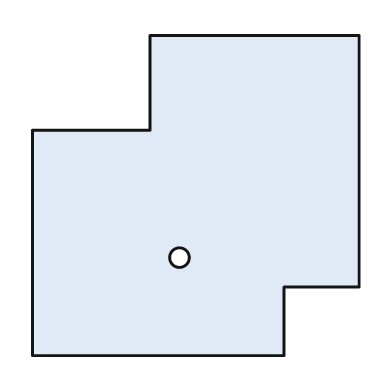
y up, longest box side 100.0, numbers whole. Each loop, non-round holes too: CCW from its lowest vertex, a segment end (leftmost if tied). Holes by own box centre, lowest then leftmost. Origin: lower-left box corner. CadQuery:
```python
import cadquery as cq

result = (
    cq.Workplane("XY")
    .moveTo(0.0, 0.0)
    .lineTo(77.0, 0.0)
    .lineTo(77.0, 21.0)
    .lineTo(100.0, 21.0)
    .lineTo(100.0, 98.0)
    .lineTo(36.0, 98.0)
    .lineTo(36.0, 69.0)
    .lineTo(0.0, 69.0)
    .close()
    .moveTo(45.0, 30.0)
    .circle(3.0)
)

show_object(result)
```